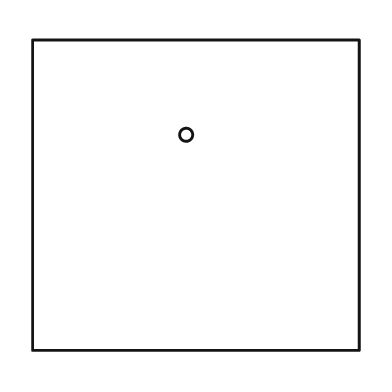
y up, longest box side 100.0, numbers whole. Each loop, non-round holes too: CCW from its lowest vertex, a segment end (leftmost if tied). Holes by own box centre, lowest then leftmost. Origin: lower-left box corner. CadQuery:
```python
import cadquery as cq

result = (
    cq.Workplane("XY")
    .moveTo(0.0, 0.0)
    .lineTo(100.0, 0.0)
    .lineTo(100.0, 95.0)
    .lineTo(0.0, 95.0)
    .close()
    .moveTo(47.0, 66.0)
    .circle(2.0)
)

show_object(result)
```